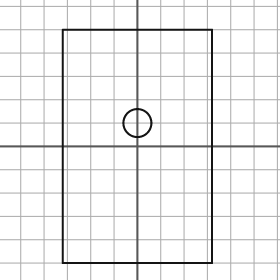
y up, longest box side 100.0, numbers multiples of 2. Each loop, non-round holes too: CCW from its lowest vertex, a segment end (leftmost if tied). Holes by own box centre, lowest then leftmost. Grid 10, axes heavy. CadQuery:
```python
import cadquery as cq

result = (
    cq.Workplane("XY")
    .moveTo(-32.0, -50.0)
    .lineTo(32.0, -50.0)
    .lineTo(32.0, 50.0)
    .lineTo(-32.0, 50.0)
    .close()
    .moveTo(0.0, 10.0)
    .circle(6.0)
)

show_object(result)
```